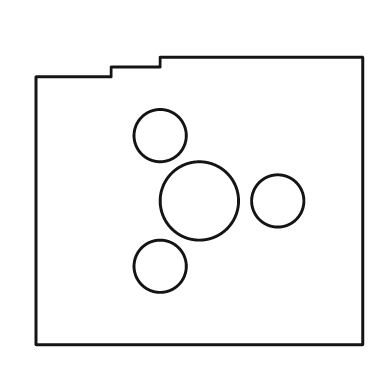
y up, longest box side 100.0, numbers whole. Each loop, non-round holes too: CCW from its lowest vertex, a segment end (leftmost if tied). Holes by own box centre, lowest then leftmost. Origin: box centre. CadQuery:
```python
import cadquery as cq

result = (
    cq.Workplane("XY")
    .moveTo(-50.0, -44.0)
    .lineTo(50.0, -44.0)
    .lineTo(50.0, 44.0)
    .lineTo(-12.0, 44.0)
    .lineTo(-12.0, 41.0)
    .lineTo(-27.0, 41.0)
    .lineTo(-27.0, 38.0)
    .lineTo(-50.0, 38.0)
    .close()
    .moveTo(-12.0, -20.0)
    .circle(8.0)
    .moveTo(0.0, 0.0)
    .circle(12.0)
    .moveTo(24.0, 0.0)
    .circle(8.0)
    .moveTo(-12.0, 20.0)
    .circle(8.0)
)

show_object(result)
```